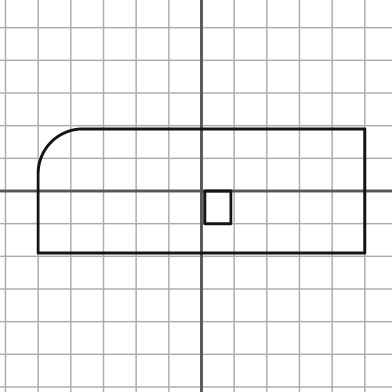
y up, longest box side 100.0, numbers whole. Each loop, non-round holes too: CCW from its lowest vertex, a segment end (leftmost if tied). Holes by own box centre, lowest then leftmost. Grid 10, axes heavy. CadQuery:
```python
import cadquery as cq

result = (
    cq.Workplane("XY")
    .moveTo(-50.0, -19.0)
    .lineTo(50.0, -19.0)
    .lineTo(50.0, 19.0)
    .lineTo(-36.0, 19.0)
    .threePointArc((-46.0, 15.0), (-50.0, 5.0))
    .close()
    .moveTo(1.0, -10.0)
    .lineTo(9.0, -10.0)
    .lineTo(9.0, 0.0)
    .lineTo(1.0, 0.0)
    .close()
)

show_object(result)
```